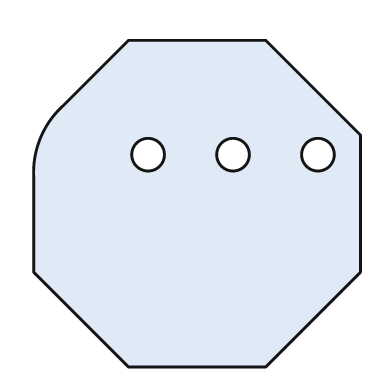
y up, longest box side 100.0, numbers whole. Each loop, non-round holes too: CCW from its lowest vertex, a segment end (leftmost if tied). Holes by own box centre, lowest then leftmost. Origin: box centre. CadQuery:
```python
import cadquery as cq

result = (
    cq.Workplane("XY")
    .moveTo(-21.0, -50.0)
    .lineTo(21.0, -50.0)
    .lineTo(50.0, -21.0)
    .lineTo(50.0, 21.0)
    .lineTo(21.0, 50.0)
    .lineTo(-21.0, 50.0)
    .lineTo(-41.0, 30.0)
    .threePointArc((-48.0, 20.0), (-50.0, 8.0))
    .lineTo(-50.0, -21.0)
    .close()
    .moveTo(-15.0, 15.0)
    .circle(5.0)
    .moveTo(11.0, 15.0)
    .circle(5.0)
    .moveTo(37.0, 15.0)
    .circle(5.0)
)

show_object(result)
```